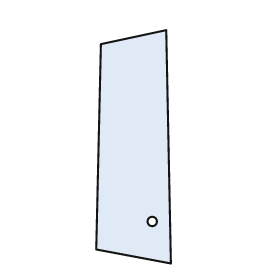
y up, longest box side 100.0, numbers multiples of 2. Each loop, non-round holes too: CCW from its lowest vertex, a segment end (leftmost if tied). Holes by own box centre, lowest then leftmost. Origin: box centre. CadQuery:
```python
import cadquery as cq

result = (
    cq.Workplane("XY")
    .moveTo(16.0, -50.0)
    .lineTo(14.0, 50.0)
    .lineTo(-14.0, 44.0)
    .lineTo(-16.0, -44.0)
    .close()
    .moveTo(8.0, -32.0)
    .circle(2.0)
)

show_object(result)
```